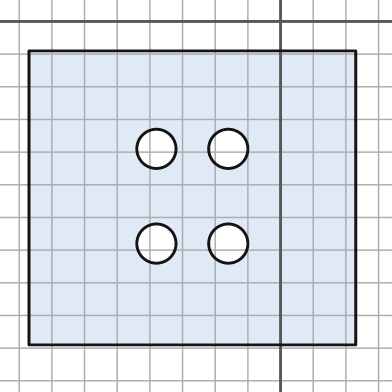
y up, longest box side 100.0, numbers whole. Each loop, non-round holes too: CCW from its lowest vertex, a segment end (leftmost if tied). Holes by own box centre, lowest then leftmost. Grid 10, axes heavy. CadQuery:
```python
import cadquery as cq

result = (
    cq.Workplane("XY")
    .moveTo(-77.0, -99.0)
    .lineTo(23.0, -99.0)
    .lineTo(23.0, -9.0)
    .lineTo(-77.0, -9.0)
    .close()
    .moveTo(-38.0, -68.0)
    .circle(6.0)
    .moveTo(-16.0, -68.0)
    .circle(6.0)
    .moveTo(-38.0, -39.0)
    .circle(6.0)
    .moveTo(-16.0, -39.0)
    .circle(6.0)
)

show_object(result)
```